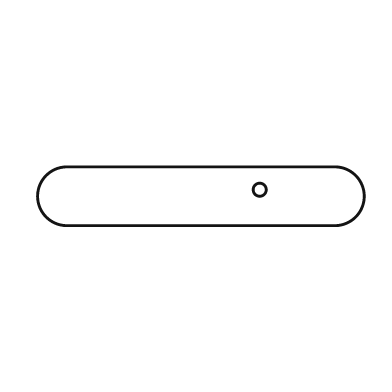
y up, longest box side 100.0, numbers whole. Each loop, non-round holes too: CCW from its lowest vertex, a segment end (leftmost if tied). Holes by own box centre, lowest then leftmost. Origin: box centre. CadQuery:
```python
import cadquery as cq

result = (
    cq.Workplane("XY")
    .moveTo(-41.0, -9.0)
    .lineTo(41.0, -9.0)
    .threePointArc((50.0, 0.0), (41.0, 9.0))
    .lineTo(-41.0, 9.0)
    .threePointArc((-50.0, 0.0), (-41.0, -9.0))
    .close()
    .moveTo(18.0, 2.0)
    .circle(2.0)
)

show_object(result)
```